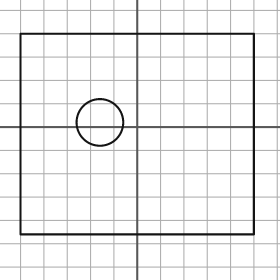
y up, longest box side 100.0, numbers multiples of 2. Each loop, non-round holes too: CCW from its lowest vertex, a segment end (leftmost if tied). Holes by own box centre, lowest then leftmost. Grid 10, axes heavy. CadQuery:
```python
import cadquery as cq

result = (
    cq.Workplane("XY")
    .moveTo(-50.0, -46.0)
    .lineTo(50.0, -46.0)
    .lineTo(50.0, 40.0)
    .lineTo(-50.0, 40.0)
    .close()
    .moveTo(-16.0, 2.0)
    .circle(10.0)
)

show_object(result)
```